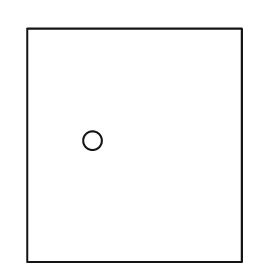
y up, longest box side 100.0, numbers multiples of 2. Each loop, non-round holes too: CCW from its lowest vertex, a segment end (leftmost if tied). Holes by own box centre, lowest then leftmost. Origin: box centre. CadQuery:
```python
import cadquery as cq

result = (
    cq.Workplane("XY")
    .moveTo(-46.0, -50.0)
    .lineTo(46.0, -50.0)
    .lineTo(46.0, 50.0)
    .lineTo(-46.0, 50.0)
    .close()
    .moveTo(-18.0, 2.0)
    .circle(4.0)
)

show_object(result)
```